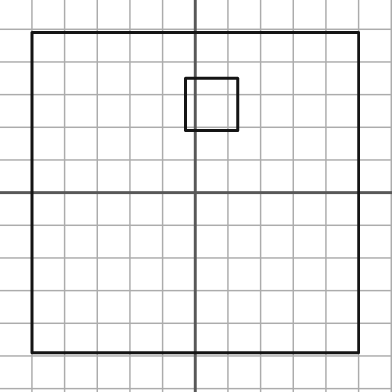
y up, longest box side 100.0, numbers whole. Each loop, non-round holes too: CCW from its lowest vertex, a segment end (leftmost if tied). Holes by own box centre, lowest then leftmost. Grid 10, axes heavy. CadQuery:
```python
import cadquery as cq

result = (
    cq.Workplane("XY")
    .moveTo(-50.0, -49.0)
    .lineTo(50.0, -49.0)
    .lineTo(50.0, 49.0)
    .lineTo(-50.0, 49.0)
    .close()
    .moveTo(-3.0, 19.0)
    .lineTo(13.0, 19.0)
    .lineTo(13.0, 35.0)
    .lineTo(-3.0, 35.0)
    .close()
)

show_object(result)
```